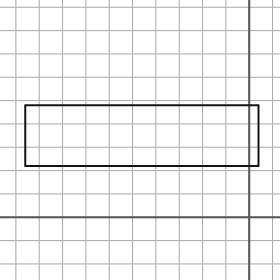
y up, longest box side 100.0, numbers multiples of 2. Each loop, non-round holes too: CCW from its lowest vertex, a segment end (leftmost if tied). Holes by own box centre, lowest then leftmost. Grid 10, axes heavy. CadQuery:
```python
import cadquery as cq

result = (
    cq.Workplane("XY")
    .moveTo(-96.0, 22.0)
    .lineTo(4.0, 22.0)
    .lineTo(4.0, 48.0)
    .lineTo(-96.0, 48.0)
    .close()
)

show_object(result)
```